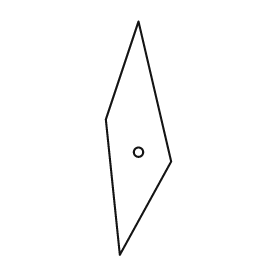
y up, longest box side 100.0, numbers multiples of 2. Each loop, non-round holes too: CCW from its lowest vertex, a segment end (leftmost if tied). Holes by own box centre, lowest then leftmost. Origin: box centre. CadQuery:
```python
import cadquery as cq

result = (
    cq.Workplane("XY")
    .moveTo(-8.0, -50.0)
    .lineTo(14.0, -10.0)
    .lineTo(0.0, 50.0)
    .lineTo(-14.0, 8.0)
    .close()
    .moveTo(0.0, -6.0)
    .circle(2.0)
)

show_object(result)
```